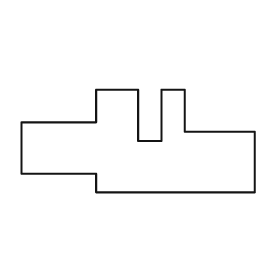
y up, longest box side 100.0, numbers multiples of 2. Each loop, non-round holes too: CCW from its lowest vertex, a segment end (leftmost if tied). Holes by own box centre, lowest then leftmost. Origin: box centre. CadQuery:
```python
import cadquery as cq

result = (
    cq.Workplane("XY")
    .moveTo(-18.0, -22.0)
    .lineTo(50.0, -22.0)
    .lineTo(50.0, 4.0)
    .lineTo(20.0, 4.0)
    .lineTo(20.0, 22.0)
    .lineTo(10.0, 22.0)
    .lineTo(10.0, 0.0)
    .lineTo(0.0, 0.0)
    .lineTo(0.0, 22.0)
    .lineTo(-18.0, 22.0)
    .lineTo(-18.0, 8.0)
    .lineTo(-50.0, 8.0)
    .lineTo(-50.0, -14.0)
    .lineTo(-18.0, -14.0)
    .close()
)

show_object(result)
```